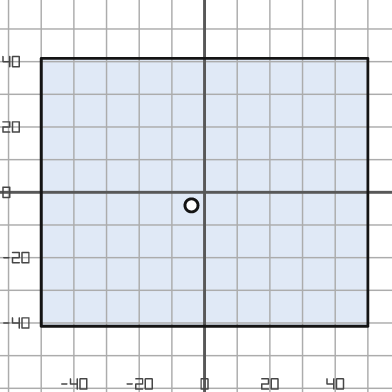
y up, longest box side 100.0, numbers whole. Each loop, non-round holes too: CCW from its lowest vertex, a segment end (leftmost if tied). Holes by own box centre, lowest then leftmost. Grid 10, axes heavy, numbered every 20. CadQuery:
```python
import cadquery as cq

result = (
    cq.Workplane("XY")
    .moveTo(-50.0, -41.0)
    .lineTo(50.0, -41.0)
    .lineTo(50.0, 41.0)
    .lineTo(-50.0, 41.0)
    .close()
    .moveTo(-4.0, -4.0)
    .circle(2.0)
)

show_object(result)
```